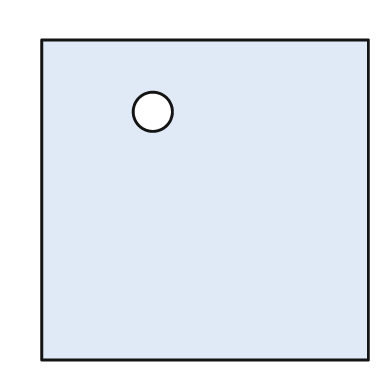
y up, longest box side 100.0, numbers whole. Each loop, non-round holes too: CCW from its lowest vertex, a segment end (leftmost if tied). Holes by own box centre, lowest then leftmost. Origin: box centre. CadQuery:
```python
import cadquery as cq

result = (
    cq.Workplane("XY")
    .moveTo(-50.0, -49.0)
    .lineTo(50.0, -49.0)
    .lineTo(50.0, 49.0)
    .lineTo(-50.0, 49.0)
    .close()
    .moveTo(-16.0, 27.0)
    .circle(6.0)
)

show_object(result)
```